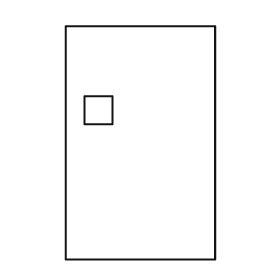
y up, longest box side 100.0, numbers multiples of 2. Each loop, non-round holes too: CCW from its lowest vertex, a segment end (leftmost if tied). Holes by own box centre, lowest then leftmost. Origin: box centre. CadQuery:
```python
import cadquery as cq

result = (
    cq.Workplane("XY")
    .moveTo(-32.0, -50.0)
    .lineTo(32.0, -50.0)
    .lineTo(32.0, 50.0)
    .lineTo(-32.0, 50.0)
    .close()
    .moveTo(-24.0, 8.0)
    .lineTo(-12.0, 8.0)
    .lineTo(-12.0, 20.0)
    .lineTo(-24.0, 20.0)
    .close()
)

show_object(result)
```